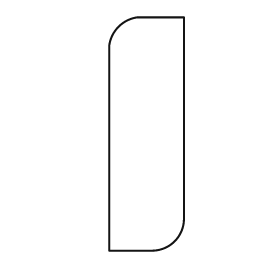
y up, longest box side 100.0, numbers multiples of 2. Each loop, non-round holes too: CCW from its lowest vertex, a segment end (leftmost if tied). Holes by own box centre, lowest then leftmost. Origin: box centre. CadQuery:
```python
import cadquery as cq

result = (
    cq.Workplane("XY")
    .moveTo(-16.0, -50.0)
    .lineTo(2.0, -50.0)
    .threePointArc((12.0, -46.0), (16.0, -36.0))
    .lineTo(16.0, 50.0)
    .lineTo(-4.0, 50.0)
    .threePointArc((-12.0, 46.0), (-16.0, 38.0))
    .close()
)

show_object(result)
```